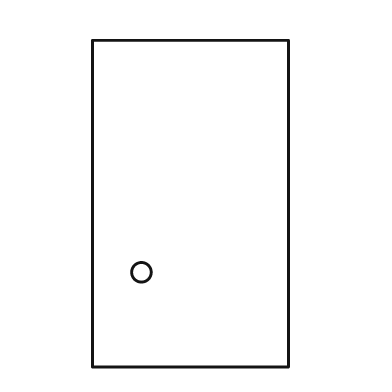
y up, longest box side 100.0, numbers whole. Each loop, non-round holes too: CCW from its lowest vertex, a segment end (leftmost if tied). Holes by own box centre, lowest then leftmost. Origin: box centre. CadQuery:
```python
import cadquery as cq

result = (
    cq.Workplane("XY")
    .moveTo(-30.0, -50.0)
    .lineTo(30.0, -50.0)
    .lineTo(30.0, 50.0)
    .lineTo(-30.0, 50.0)
    .close()
    .moveTo(-15.0, -21.0)
    .circle(3.0)
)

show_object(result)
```